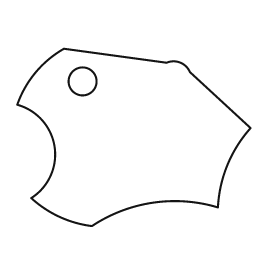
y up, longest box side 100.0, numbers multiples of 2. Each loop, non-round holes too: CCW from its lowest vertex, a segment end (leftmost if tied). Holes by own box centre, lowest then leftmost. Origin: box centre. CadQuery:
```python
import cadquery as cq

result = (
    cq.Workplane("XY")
    .moveTo(-18.0, -38.0)
    .threePointArc((8.0, -28.0), (36.0, -30.0))
    .threePointArc((40.0, -12.0), (50.0, 4.0))
    .lineTo(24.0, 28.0)
    .threePointArc((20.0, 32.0), (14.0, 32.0))
    .lineTo(-30.0, 38.0)
    .threePointArc((-42.0, 28.0), (-50.0, 14.0))
    .threePointArc((-34.0, -4.0), (-44.0, -26.0))
    .threePointArc((-32.0, -34.0), (-18.0, -38.0))
    .close()
    .moveTo(-22.0, 24.0)
    .circle(6.0)
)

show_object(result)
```